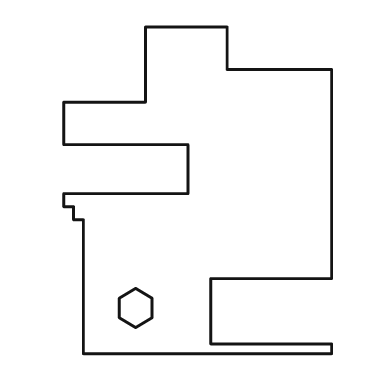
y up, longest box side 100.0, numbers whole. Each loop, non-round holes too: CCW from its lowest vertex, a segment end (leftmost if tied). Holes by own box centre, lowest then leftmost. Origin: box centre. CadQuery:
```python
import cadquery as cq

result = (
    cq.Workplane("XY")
    .moveTo(-35.0, -50.0)
    .lineTo(41.0, -50.0)
    .lineTo(41.0, -47.0)
    .lineTo(4.0, -47.0)
    .lineTo(4.0, -27.0)
    .lineTo(41.0, -27.0)
    .lineTo(41.0, 37.0)
    .lineTo(9.0, 37.0)
    .lineTo(9.0, 50.0)
    .lineTo(-16.0, 50.0)
    .lineTo(-16.0, 27.0)
    .lineTo(-41.0, 27.0)
    .lineTo(-41.0, 14.0)
    .lineTo(-3.0, 14.0)
    .lineTo(-3.0, -1.0)
    .lineTo(-41.0, -1.0)
    .lineTo(-41.0, -5.0)
    .lineTo(-38.0, -5.0)
    .lineTo(-38.0, -9.0)
    .lineTo(-35.0, -9.0)
    .close()
    .moveTo(-19.0, -42.0)
    .lineTo(-14.0, -39.0)
    .lineTo(-14.0, -33.0)
    .lineTo(-19.0, -30.0)
    .lineTo(-24.0, -33.0)
    .lineTo(-24.0, -39.0)
    .close()
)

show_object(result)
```